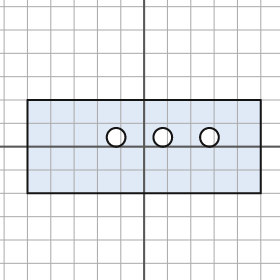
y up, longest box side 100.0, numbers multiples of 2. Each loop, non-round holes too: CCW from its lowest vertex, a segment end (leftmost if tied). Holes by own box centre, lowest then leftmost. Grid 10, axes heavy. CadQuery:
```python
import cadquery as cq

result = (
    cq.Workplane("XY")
    .moveTo(-50.0, -20.0)
    .lineTo(50.0, -20.0)
    .lineTo(50.0, 20.0)
    .lineTo(-50.0, 20.0)
    .close()
    .moveTo(-12.0, 4.0)
    .circle(4.0)
    .moveTo(8.0, 4.0)
    .circle(4.0)
    .moveTo(28.0, 4.0)
    .circle(4.0)
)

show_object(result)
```